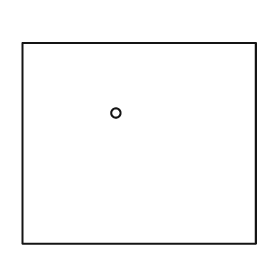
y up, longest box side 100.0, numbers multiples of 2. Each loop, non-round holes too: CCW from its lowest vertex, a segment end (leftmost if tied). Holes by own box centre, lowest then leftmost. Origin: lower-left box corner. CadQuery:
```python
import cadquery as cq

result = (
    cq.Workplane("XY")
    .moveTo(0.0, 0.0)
    .lineTo(100.0, 0.0)
    .lineTo(100.0, 86.0)
    .lineTo(0.0, 86.0)
    .close()
    .moveTo(40.0, 56.0)
    .circle(2.0)
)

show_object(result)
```